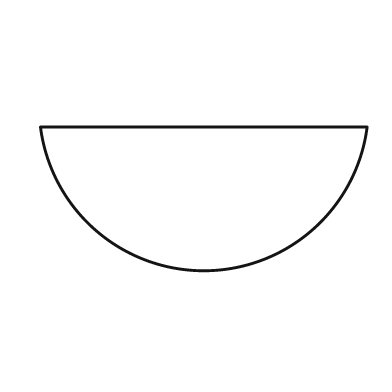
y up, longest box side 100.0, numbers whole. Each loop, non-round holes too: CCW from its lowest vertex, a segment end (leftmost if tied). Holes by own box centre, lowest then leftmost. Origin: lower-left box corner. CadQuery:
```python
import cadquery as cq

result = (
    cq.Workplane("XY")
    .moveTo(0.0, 44.0)
    .threePointArc((50.0, 0.0), (100.0, 44.0))
    .close()
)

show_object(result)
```